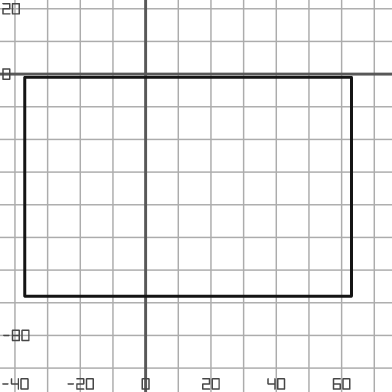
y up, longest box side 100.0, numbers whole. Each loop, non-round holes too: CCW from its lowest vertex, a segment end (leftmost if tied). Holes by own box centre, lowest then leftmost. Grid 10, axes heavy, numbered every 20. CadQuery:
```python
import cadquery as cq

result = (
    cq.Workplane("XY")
    .moveTo(-37.0, -68.0)
    .lineTo(63.0, -68.0)
    .lineTo(63.0, -1.0)
    .lineTo(-37.0, -1.0)
    .close()
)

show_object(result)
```